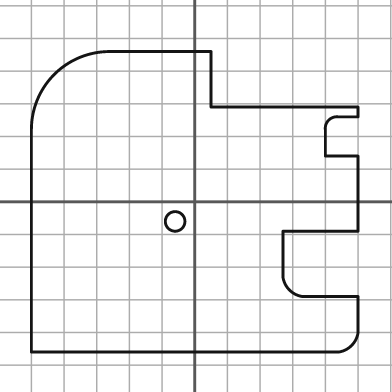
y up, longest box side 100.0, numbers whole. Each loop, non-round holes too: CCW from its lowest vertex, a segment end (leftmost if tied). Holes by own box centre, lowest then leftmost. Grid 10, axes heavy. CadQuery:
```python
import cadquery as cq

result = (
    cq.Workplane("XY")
    .moveTo(-50.0, -46.0)
    .lineTo(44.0, -46.0)
    .threePointArc((48.0, -44.0), (50.0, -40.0))
    .lineTo(50.0, -29.0)
    .lineTo(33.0, -29.0)
    .threePointArc((29.0, -27.0), (27.0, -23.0))
    .lineTo(27.0, -9.0)
    .lineTo(50.0, -9.0)
    .lineTo(50.0, 14.0)
    .lineTo(40.0, 14.0)
    .lineTo(40.0, 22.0)
    .threePointArc((41.0, 25.0), (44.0, 26.0))
    .lineTo(50.0, 26.0)
    .lineTo(50.0, 29.0)
    .lineTo(5.0, 29.0)
    .lineTo(5.0, 46.0)
    .lineTo(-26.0, 46.0)
    .threePointArc((-43.0, 39.0), (-50.0, 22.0))
    .close()
    .moveTo(-6.0, -6.0)
    .circle(3.0)
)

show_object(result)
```